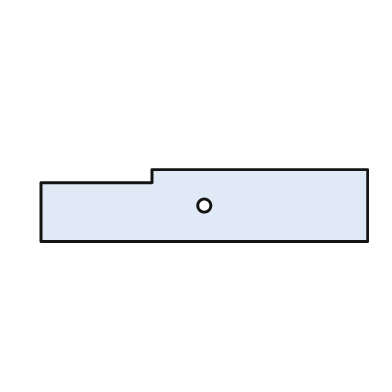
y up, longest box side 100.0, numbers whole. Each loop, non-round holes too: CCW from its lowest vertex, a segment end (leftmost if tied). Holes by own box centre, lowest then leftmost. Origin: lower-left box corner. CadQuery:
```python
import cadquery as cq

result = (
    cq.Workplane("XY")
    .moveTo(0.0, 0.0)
    .lineTo(100.0, 0.0)
    .lineTo(100.0, 22.0)
    .lineTo(34.0, 22.0)
    .lineTo(34.0, 18.0)
    .lineTo(0.0, 18.0)
    .close()
    .moveTo(50.0, 11.0)
    .circle(2.0)
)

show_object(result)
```